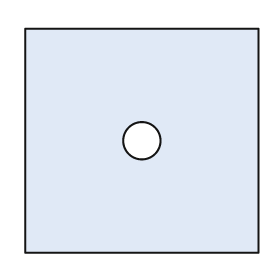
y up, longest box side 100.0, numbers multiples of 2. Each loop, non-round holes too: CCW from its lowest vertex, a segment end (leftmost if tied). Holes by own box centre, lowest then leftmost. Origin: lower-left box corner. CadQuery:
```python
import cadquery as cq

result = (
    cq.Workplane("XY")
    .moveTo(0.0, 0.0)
    .lineTo(100.0, 0.0)
    .lineTo(100.0, 96.0)
    .lineTo(0.0, 96.0)
    .close()
    .moveTo(50.0, 48.0)
    .circle(8.0)
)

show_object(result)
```